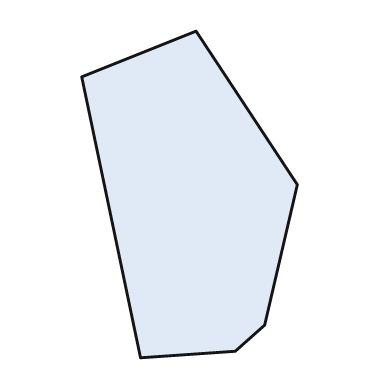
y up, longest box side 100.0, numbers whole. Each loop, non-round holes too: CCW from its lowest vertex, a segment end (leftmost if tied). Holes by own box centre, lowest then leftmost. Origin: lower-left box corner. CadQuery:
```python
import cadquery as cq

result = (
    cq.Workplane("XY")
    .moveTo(18.0, 0.0)
    .lineTo(47.0, 2.0)
    .lineTo(56.0, 10.0)
    .lineTo(66.0, 53.0)
    .lineTo(35.0, 100.0)
    .lineTo(0.0, 86.0)
    .close()
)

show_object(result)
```